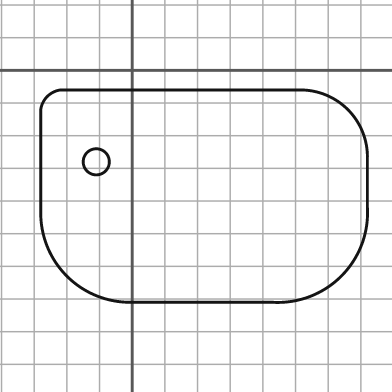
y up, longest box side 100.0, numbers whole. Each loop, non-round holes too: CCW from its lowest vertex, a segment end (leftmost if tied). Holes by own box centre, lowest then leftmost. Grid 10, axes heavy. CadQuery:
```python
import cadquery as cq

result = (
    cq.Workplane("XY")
    .moveTo(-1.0, -71.0)
    .lineTo(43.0, -71.0)
    .threePointArc((64.0, -63.0), (72.0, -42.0))
    .lineTo(72.0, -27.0)
    .threePointArc((66.0, -12.0), (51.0, -6.0))
    .lineTo(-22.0, -6.0)
    .threePointArc((-26.0, -8.0), (-28.0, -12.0))
    .lineTo(-28.0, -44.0)
    .threePointArc((-20.0, -63.0), (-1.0, -71.0))
    .close()
    .moveTo(-11.0, -28.0)
    .circle(4.0)
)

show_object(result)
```